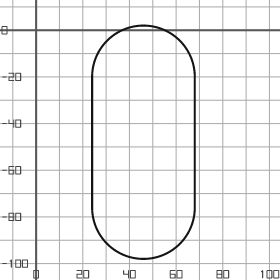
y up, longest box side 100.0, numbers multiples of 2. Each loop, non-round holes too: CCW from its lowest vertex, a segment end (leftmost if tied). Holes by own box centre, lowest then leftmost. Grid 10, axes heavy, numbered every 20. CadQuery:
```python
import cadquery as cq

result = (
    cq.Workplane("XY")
    .moveTo(24.0, -76.0)
    .threePointArc((46.0, -98.0), (68.0, -76.0))
    .lineTo(68.0, -20.0)
    .threePointArc((46.0, 2.0), (24.0, -20.0))
    .close()
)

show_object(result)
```